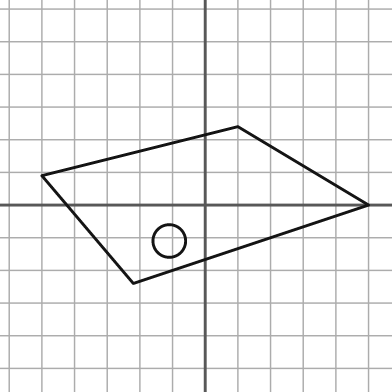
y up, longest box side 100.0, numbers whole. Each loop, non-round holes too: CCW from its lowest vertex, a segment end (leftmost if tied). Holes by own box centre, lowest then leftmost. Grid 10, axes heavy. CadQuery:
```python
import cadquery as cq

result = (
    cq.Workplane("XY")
    .moveTo(-22.0, -24.0)
    .lineTo(50.0, 0.0)
    .lineTo(10.0, 24.0)
    .lineTo(-50.0, 9.0)
    .close()
    .moveTo(-11.0, -11.0)
    .circle(5.0)
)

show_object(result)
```